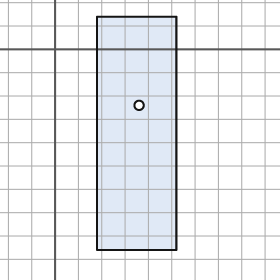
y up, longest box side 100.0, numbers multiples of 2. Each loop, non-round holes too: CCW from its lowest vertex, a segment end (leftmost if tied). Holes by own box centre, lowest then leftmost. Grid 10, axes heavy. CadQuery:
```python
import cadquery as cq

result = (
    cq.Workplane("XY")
    .moveTo(18.0, -86.0)
    .lineTo(52.0, -86.0)
    .lineTo(52.0, 14.0)
    .lineTo(18.0, 14.0)
    .close()
    .moveTo(36.0, -24.0)
    .circle(2.0)
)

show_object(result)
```